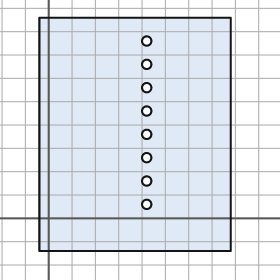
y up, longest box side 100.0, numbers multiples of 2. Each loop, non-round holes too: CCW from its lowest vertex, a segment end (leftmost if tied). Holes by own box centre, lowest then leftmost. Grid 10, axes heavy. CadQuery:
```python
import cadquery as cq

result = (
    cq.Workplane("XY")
    .moveTo(-4.0, -14.0)
    .lineTo(78.0, -14.0)
    .lineTo(78.0, 86.0)
    .lineTo(-4.0, 86.0)
    .close()
    .moveTo(42.0, 6.0)
    .circle(2.0)
    .moveTo(42.0, 16.0)
    .circle(2.0)
    .moveTo(42.0, 26.0)
    .circle(2.0)
    .moveTo(42.0, 36.0)
    .circle(2.0)
    .moveTo(42.0, 46.0)
    .circle(2.0)
    .moveTo(42.0, 56.0)
    .circle(2.0)
    .moveTo(42.0, 66.0)
    .circle(2.0)
    .moveTo(42.0, 76.0)
    .circle(2.0)
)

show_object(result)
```